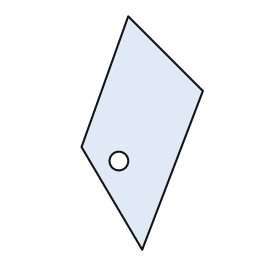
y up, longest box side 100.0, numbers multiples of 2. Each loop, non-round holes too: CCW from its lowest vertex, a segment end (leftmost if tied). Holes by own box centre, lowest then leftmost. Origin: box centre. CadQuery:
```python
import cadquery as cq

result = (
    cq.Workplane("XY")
    .moveTo(0.0, -50.0)
    .lineTo(26.0, 18.0)
    .lineTo(-6.0, 50.0)
    .lineTo(-26.0, -6.0)
    .close()
    .moveTo(-10.0, -12.0)
    .circle(4.0)
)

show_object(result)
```